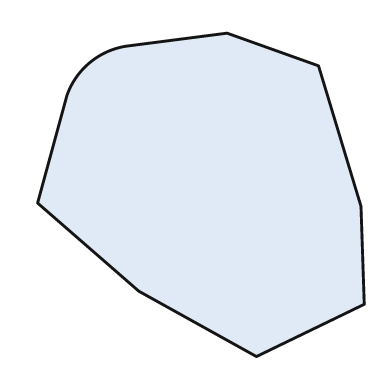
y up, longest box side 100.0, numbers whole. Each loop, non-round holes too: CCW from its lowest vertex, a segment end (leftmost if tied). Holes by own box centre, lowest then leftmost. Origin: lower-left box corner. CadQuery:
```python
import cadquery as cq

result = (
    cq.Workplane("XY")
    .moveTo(67.0, 0.0)
    .lineTo(100.0, 16.0)
    .lineTo(99.0, 46.0)
    .lineTo(86.0, 89.0)
    .lineTo(58.0, 99.0)
    .lineTo(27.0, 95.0)
    .threePointArc((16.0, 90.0), (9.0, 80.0))
    .lineTo(0.0, 47.0)
    .lineTo(31.0, 20.0)
    .close()
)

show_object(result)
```